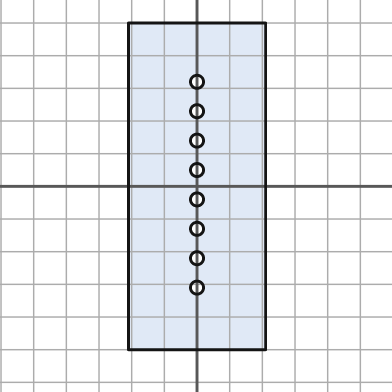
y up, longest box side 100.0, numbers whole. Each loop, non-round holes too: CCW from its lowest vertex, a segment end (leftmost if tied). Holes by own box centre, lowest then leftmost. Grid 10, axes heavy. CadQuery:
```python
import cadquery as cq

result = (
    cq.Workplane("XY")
    .moveTo(-21.0, -50.0)
    .lineTo(21.0, -50.0)
    .lineTo(21.0, 50.0)
    .lineTo(-21.0, 50.0)
    .close()
    .moveTo(0.0, -31.0)
    .circle(2.0)
    .moveTo(0.0, -22.0)
    .circle(2.0)
    .moveTo(0.0, -13.0)
    .circle(2.0)
    .moveTo(0.0, -4.0)
    .circle(2.0)
    .moveTo(0.0, 5.0)
    .circle(2.0)
    .moveTo(0.0, 14.0)
    .circle(2.0)
    .moveTo(0.0, 23.0)
    .circle(2.0)
    .moveTo(0.0, 32.0)
    .circle(2.0)
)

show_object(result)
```